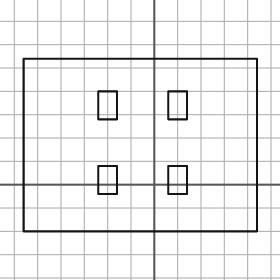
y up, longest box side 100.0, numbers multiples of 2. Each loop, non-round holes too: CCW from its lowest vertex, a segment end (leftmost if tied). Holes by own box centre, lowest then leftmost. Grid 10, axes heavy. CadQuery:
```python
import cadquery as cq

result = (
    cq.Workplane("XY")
    .moveTo(-56.0, -20.0)
    .lineTo(44.0, -20.0)
    .lineTo(44.0, 54.0)
    .lineTo(-56.0, 54.0)
    .close()
    .moveTo(-24.0, -4.0)
    .lineTo(-16.0, -4.0)
    .lineTo(-16.0, 8.0)
    .lineTo(-24.0, 8.0)
    .close()
    .moveTo(6.0, -4.0)
    .lineTo(14.0, -4.0)
    .lineTo(14.0, 8.0)
    .lineTo(6.0, 8.0)
    .close()
    .moveTo(-24.0, 28.0)
    .lineTo(-16.0, 28.0)
    .lineTo(-16.0, 40.0)
    .lineTo(-24.0, 40.0)
    .close()
    .moveTo(6.0, 28.0)
    .lineTo(14.0, 28.0)
    .lineTo(14.0, 40.0)
    .lineTo(6.0, 40.0)
    .close()
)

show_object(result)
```